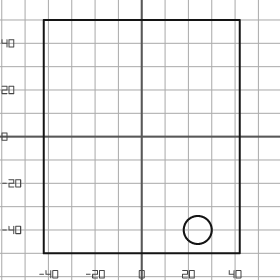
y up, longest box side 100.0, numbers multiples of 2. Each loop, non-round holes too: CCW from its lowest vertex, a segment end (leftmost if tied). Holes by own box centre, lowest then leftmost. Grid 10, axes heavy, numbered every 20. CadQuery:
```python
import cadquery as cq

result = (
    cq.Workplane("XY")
    .moveTo(-42.0, -50.0)
    .lineTo(42.0, -50.0)
    .lineTo(42.0, 50.0)
    .lineTo(-42.0, 50.0)
    .close()
    .moveTo(24.0, -40.0)
    .circle(6.0)
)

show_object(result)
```